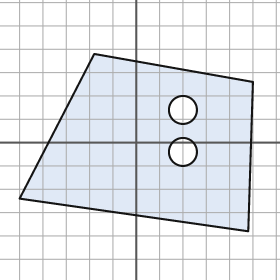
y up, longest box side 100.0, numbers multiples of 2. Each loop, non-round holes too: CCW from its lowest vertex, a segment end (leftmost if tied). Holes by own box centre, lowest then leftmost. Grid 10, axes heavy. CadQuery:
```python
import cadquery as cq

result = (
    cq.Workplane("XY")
    .moveTo(48.0, -38.0)
    .lineTo(50.0, 26.0)
    .lineTo(-18.0, 38.0)
    .lineTo(-50.0, -24.0)
    .close()
    .moveTo(20.0, -4.0)
    .circle(6.0)
    .moveTo(20.0, 14.0)
    .circle(6.0)
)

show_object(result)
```